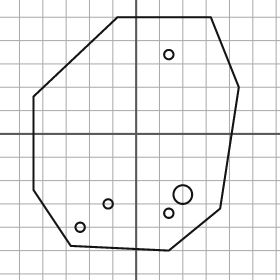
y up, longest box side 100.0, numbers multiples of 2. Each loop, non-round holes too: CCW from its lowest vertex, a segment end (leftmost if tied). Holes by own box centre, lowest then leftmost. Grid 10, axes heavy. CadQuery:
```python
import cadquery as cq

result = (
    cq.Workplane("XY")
    .moveTo(14.0, -50.0)
    .lineTo(36.0, -32.0)
    .lineTo(44.0, 20.0)
    .lineTo(32.0, 50.0)
    .lineTo(-8.0, 50.0)
    .lineTo(-44.0, 16.0)
    .lineTo(-44.0, -24.0)
    .lineTo(-28.0, -48.0)
    .close()
    .moveTo(-24.0, -40.0)
    .circle(2.0)
    .moveTo(14.0, -34.0)
    .circle(2.0)
    .moveTo(-12.0, -30.0)
    .circle(2.0)
    .moveTo(20.0, -26.0)
    .circle(4.0)
    .moveTo(14.0, 34.0)
    .circle(2.0)
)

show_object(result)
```